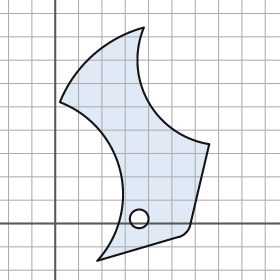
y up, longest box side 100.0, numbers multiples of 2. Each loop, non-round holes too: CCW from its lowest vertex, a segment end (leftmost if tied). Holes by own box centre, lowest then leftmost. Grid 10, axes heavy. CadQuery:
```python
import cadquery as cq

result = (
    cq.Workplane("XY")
    .moveTo(18.0, -16.0)
    .lineTo(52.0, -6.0)
    .threePointArc((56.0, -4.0), (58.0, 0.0))
    .lineTo(66.0, 34.0)
    .threePointArc((40.0, 52.0), (38.0, 84.0))
    .threePointArc((16.0, 72.0), (2.0, 52.0))
    .threePointArc((28.0, 22.0), (18.0, -16.0))
    .close()
    .moveTo(36.0, 2.0)
    .circle(4.0)
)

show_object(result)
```